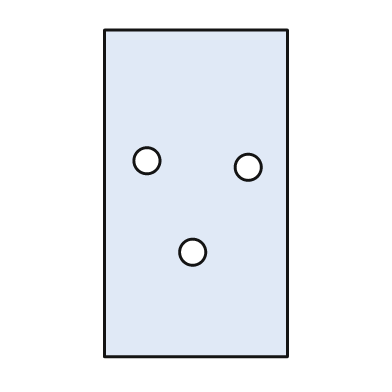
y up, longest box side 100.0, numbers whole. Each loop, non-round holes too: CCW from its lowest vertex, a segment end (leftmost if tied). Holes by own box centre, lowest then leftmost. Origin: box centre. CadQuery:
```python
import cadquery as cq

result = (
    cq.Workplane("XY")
    .moveTo(-28.0, -50.0)
    .lineTo(28.0, -50.0)
    .lineTo(28.0, 50.0)
    .lineTo(-28.0, 50.0)
    .close()
    .moveTo(-1.0, -18.0)
    .circle(4.0)
    .moveTo(16.0, 8.0)
    .circle(4.0)
    .moveTo(-15.0, 10.0)
    .circle(4.0)
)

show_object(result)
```